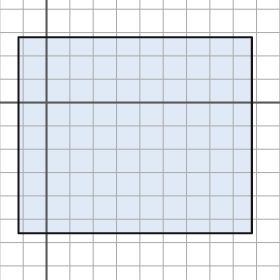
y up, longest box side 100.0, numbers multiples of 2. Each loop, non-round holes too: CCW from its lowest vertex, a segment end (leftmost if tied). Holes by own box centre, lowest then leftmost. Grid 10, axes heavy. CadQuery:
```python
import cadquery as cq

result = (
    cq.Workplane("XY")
    .moveTo(-12.0, -56.0)
    .lineTo(88.0, -56.0)
    .lineTo(88.0, 28.0)
    .lineTo(-12.0, 28.0)
    .close()
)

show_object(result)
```